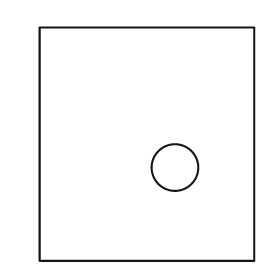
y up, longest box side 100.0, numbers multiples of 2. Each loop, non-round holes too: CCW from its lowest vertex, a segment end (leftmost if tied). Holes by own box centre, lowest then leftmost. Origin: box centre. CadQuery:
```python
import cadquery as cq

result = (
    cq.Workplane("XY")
    .moveTo(-46.0, -50.0)
    .lineTo(46.0, -50.0)
    .lineTo(46.0, 50.0)
    .lineTo(-46.0, 50.0)
    .close()
    .moveTo(12.0, -10.0)
    .circle(10.0)
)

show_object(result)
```